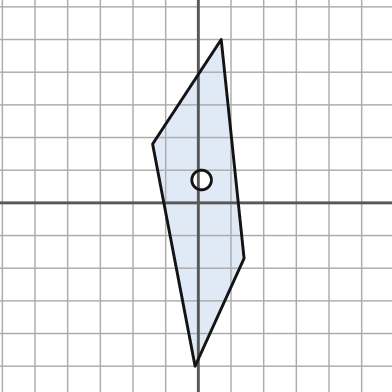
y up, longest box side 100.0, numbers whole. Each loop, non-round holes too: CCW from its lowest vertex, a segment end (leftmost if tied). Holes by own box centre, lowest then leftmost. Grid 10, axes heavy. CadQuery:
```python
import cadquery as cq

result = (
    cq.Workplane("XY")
    .moveTo(-1.0, -50.0)
    .lineTo(14.0, -17.0)
    .lineTo(7.0, 50.0)
    .lineTo(-14.0, 18.0)
    .close()
    .moveTo(1.0, 7.0)
    .circle(3.0)
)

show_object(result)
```